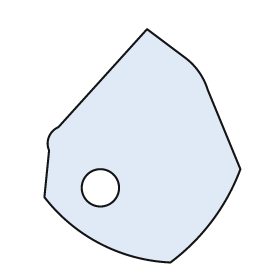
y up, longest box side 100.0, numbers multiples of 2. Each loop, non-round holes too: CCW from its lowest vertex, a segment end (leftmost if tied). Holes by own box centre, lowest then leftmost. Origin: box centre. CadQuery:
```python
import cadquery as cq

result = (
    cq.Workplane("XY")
    .moveTo(12.0, -50.0)
    .threePointArc((30.0, -32.0), (42.0, -10.0))
    .lineTo(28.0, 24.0)
    .threePointArc((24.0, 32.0), (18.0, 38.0))
    .lineTo(2.0, 50.0)
    .lineTo(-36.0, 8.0)
    .threePointArc((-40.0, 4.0), (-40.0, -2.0))
    .lineTo(-42.0, -22.0)
    .threePointArc((-18.0, -42.0), (12.0, -50.0))
    .close()
    .moveTo(-18.0, -18.0)
    .circle(8.0)
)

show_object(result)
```